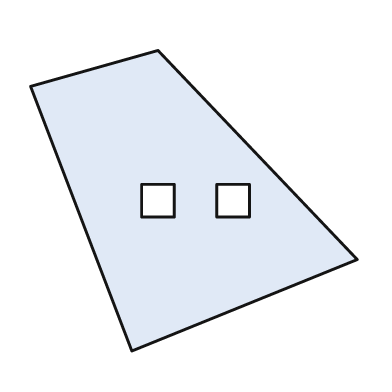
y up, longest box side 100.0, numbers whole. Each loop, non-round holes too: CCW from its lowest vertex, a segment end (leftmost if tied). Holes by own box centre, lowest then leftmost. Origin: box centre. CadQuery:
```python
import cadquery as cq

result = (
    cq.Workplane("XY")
    .moveTo(-19.0, -46.0)
    .lineTo(50.0, -18.0)
    .lineTo(-11.0, 46.0)
    .lineTo(-50.0, 35.0)
    .close()
    .moveTo(-16.0, -5.0)
    .lineTo(-6.0, -5.0)
    .lineTo(-6.0, 5.0)
    .lineTo(-16.0, 5.0)
    .close()
    .moveTo(7.0, -5.0)
    .lineTo(17.0, -5.0)
    .lineTo(17.0, 5.0)
    .lineTo(7.0, 5.0)
    .close()
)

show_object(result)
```